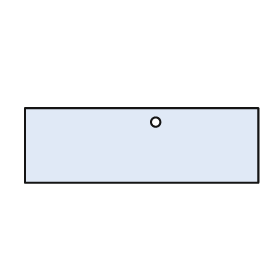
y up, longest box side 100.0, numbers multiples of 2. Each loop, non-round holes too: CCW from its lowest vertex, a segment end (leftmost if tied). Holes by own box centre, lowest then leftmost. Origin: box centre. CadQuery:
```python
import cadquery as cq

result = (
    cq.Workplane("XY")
    .moveTo(-50.0, -16.0)
    .lineTo(50.0, -16.0)
    .lineTo(50.0, 16.0)
    .lineTo(-50.0, 16.0)
    .close()
    .moveTo(6.0, 10.0)
    .circle(2.0)
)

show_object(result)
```